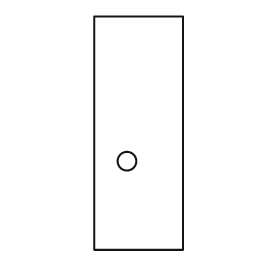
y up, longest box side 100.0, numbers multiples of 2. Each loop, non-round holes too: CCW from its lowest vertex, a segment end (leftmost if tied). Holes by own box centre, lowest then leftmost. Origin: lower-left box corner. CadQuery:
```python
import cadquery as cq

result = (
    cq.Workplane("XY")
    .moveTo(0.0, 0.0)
    .lineTo(38.0, 0.0)
    .lineTo(38.0, 100.0)
    .lineTo(0.0, 100.0)
    .close()
    .moveTo(14.0, 38.0)
    .circle(4.0)
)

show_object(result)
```